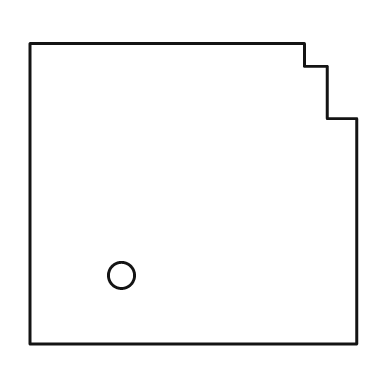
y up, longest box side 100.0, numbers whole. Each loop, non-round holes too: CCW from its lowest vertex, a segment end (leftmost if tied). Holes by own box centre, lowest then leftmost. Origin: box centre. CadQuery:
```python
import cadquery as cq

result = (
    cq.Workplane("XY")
    .moveTo(-50.0, -46.0)
    .lineTo(50.0, -46.0)
    .lineTo(50.0, 23.0)
    .lineTo(41.0, 23.0)
    .lineTo(41.0, 39.0)
    .lineTo(34.0, 39.0)
    .lineTo(34.0, 46.0)
    .lineTo(-50.0, 46.0)
    .close()
    .moveTo(-22.0, -25.0)
    .circle(4.0)
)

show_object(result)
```